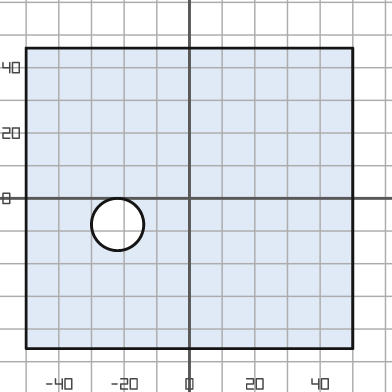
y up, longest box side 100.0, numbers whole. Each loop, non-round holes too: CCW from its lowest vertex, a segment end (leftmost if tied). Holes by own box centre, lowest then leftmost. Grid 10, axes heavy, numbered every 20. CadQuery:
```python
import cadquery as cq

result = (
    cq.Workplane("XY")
    .moveTo(-50.0, -46.0)
    .lineTo(50.0, -46.0)
    .lineTo(50.0, 46.0)
    .lineTo(-50.0, 46.0)
    .close()
    .moveTo(-22.0, -8.0)
    .circle(8.0)
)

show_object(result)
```